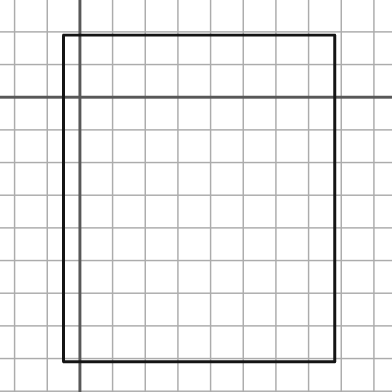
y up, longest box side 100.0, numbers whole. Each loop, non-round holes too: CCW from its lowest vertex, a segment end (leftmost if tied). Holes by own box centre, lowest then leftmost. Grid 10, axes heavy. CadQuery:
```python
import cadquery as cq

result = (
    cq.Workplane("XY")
    .moveTo(-5.0, -81.0)
    .lineTo(78.0, -81.0)
    .lineTo(78.0, 19.0)
    .lineTo(-5.0, 19.0)
    .close()
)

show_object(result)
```